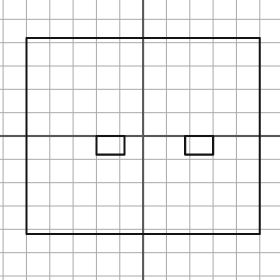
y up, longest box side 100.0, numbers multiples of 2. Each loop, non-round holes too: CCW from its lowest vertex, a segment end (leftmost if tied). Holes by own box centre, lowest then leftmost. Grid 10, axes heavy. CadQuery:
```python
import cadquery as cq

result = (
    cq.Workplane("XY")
    .moveTo(-50.0, -42.0)
    .lineTo(50.0, -42.0)
    .lineTo(50.0, 42.0)
    .lineTo(-50.0, 42.0)
    .close()
    .moveTo(-20.0, -8.0)
    .lineTo(-8.0, -8.0)
    .lineTo(-8.0, 0.0)
    .lineTo(-20.0, 0.0)
    .close()
    .moveTo(18.0, -8.0)
    .lineTo(30.0, -8.0)
    .lineTo(30.0, 0.0)
    .lineTo(18.0, 0.0)
    .close()
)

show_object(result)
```